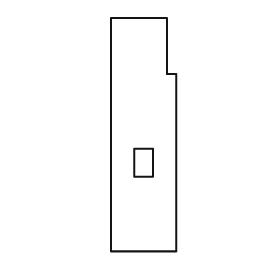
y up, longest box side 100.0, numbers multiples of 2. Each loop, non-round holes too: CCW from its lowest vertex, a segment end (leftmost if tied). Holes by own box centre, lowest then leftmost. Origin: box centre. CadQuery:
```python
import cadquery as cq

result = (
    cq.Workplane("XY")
    .moveTo(-14.0, -50.0)
    .lineTo(14.0, -50.0)
    .lineTo(14.0, 26.0)
    .lineTo(10.0, 26.0)
    .lineTo(10.0, 50.0)
    .lineTo(-14.0, 50.0)
    .close()
    .moveTo(-4.0, -18.0)
    .lineTo(4.0, -18.0)
    .lineTo(4.0, -6.0)
    .lineTo(-4.0, -6.0)
    .close()
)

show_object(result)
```